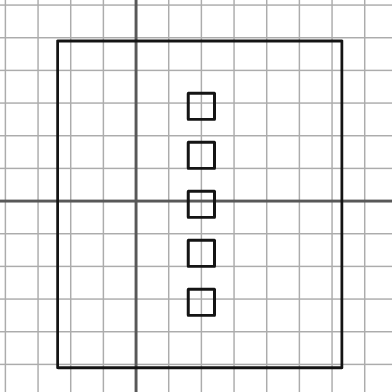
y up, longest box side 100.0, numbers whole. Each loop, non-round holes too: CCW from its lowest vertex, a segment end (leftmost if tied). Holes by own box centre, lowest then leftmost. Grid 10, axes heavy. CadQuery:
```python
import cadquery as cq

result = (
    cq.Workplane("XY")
    .moveTo(-24.0, -51.0)
    .lineTo(63.0, -51.0)
    .lineTo(63.0, 49.0)
    .lineTo(-24.0, 49.0)
    .close()
    .moveTo(16.0, -35.0)
    .lineTo(24.0, -35.0)
    .lineTo(24.0, -27.0)
    .lineTo(16.0, -27.0)
    .close()
    .moveTo(16.0, -20.0)
    .lineTo(24.0, -20.0)
    .lineTo(24.0, -12.0)
    .lineTo(16.0, -12.0)
    .close()
    .moveTo(16.0, -5.0)
    .lineTo(24.0, -5.0)
    .lineTo(24.0, 3.0)
    .lineTo(16.0, 3.0)
    .close()
    .moveTo(16.0, 10.0)
    .lineTo(24.0, 10.0)
    .lineTo(24.0, 18.0)
    .lineTo(16.0, 18.0)
    .close()
    .moveTo(16.0, 25.0)
    .lineTo(24.0, 25.0)
    .lineTo(24.0, 33.0)
    .lineTo(16.0, 33.0)
    .close()
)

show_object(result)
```